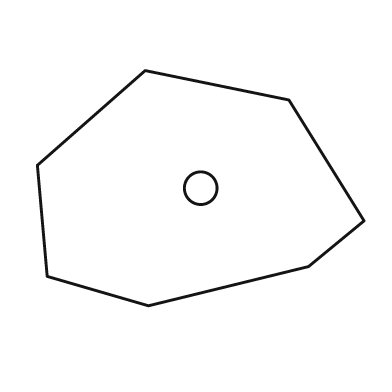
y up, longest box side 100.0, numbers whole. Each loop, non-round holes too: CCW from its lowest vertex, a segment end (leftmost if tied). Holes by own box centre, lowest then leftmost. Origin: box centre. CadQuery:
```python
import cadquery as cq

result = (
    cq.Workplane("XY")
    .moveTo(-16.0, -36.0)
    .lineTo(33.0, -24.0)
    .lineTo(50.0, -10.0)
    .lineTo(27.0, 27.0)
    .lineTo(-17.0, 36.0)
    .lineTo(-50.0, 7.0)
    .lineTo(-47.0, -27.0)
    .close()
    .moveTo(0.0, 0.0)
    .circle(5.0)
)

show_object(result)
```